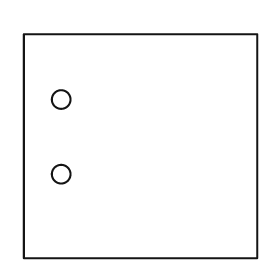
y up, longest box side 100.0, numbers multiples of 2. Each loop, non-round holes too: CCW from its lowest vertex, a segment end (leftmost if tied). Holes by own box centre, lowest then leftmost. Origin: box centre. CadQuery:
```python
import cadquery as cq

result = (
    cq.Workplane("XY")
    .moveTo(-50.0, -48.0)
    .lineTo(50.0, -48.0)
    .lineTo(50.0, 48.0)
    .lineTo(-50.0, 48.0)
    .close()
    .moveTo(-34.0, -12.0)
    .circle(4.0)
    .moveTo(-34.0, 20.0)
    .circle(4.0)
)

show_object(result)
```